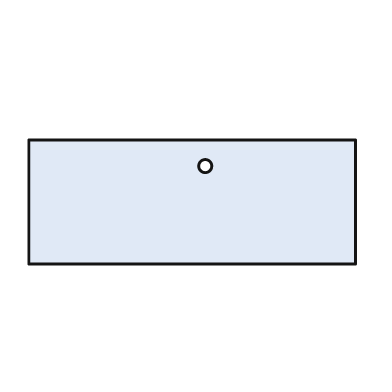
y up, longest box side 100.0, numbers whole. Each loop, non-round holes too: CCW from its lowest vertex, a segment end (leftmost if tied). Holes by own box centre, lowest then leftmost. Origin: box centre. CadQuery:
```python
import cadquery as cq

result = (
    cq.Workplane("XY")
    .moveTo(-50.0, -19.0)
    .lineTo(50.0, -19.0)
    .lineTo(50.0, 19.0)
    .lineTo(-50.0, 19.0)
    .close()
    .moveTo(4.0, 11.0)
    .circle(2.0)
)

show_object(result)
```